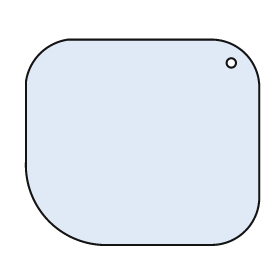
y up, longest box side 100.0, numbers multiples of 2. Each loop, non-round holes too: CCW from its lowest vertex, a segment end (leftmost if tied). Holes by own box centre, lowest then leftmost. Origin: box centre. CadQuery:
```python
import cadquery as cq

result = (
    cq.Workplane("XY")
    .moveTo(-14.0, -44.0)
    .lineTo(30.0, -44.0)
    .threePointArc((44.0, -38.0), (50.0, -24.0))
    .lineTo(50.0, 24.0)
    .threePointArc((44.0, 38.0), (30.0, 44.0))
    .lineTo(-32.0, 44.0)
    .threePointArc((-44.0, 38.0), (-50.0, 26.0))
    .lineTo(-50.0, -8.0)
    .threePointArc((-40.0, -34.0), (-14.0, -44.0))
    .close()
    .moveTo(38.0, 34.0)
    .circle(2.0)
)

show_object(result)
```